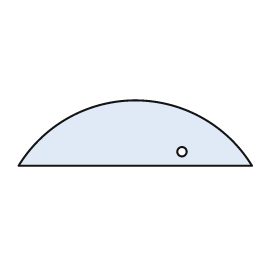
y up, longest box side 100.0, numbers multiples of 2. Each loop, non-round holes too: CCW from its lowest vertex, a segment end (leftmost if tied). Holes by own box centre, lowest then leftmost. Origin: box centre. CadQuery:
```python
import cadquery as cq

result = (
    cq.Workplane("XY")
    .moveTo(-50.0, -14.0)
    .lineTo(50.0, -14.0)
    .threePointArc((0.0, 14.0), (-50.0, -14.0))
    .close()
    .moveTo(20.0, -8.0)
    .circle(2.0)
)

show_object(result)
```